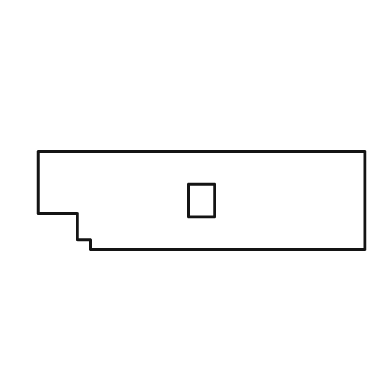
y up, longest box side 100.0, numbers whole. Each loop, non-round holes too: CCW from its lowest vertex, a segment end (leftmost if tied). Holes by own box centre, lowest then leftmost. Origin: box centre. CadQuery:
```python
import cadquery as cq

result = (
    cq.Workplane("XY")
    .moveTo(-34.0, -15.0)
    .lineTo(50.0, -15.0)
    .lineTo(50.0, 15.0)
    .lineTo(-50.0, 15.0)
    .lineTo(-50.0, -4.0)
    .lineTo(-38.0, -4.0)
    .lineTo(-38.0, -12.0)
    .lineTo(-34.0, -12.0)
    .close()
    .moveTo(-4.0, -5.0)
    .lineTo(4.0, -5.0)
    .lineTo(4.0, 5.0)
    .lineTo(-4.0, 5.0)
    .close()
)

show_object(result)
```